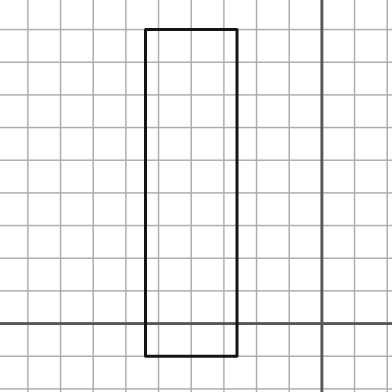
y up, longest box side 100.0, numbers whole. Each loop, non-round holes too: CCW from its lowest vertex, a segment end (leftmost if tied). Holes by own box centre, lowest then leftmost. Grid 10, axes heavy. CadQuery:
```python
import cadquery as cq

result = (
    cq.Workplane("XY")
    .moveTo(-54.0, -10.0)
    .lineTo(-26.0, -10.0)
    .lineTo(-26.0, 90.0)
    .lineTo(-54.0, 90.0)
    .close()
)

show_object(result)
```